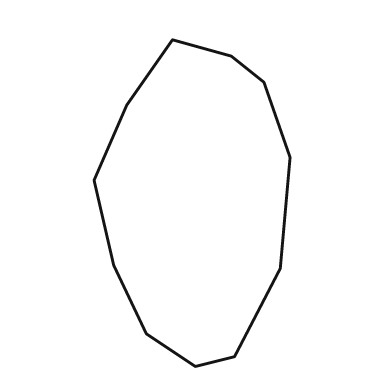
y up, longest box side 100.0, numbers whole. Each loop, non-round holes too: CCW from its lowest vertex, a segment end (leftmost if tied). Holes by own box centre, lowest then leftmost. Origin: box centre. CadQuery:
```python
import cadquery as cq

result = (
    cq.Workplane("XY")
    .moveTo(1.0, -50.0)
    .lineTo(13.0, -47.0)
    .lineTo(27.0, -20.0)
    .lineTo(30.0, 14.0)
    .lineTo(22.0, 37.0)
    .lineTo(12.0, 45.0)
    .lineTo(-6.0, 50.0)
    .lineTo(-20.0, 30.0)
    .lineTo(-30.0, 7.0)
    .lineTo(-24.0, -19.0)
    .lineTo(-14.0, -40.0)
    .close()
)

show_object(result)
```